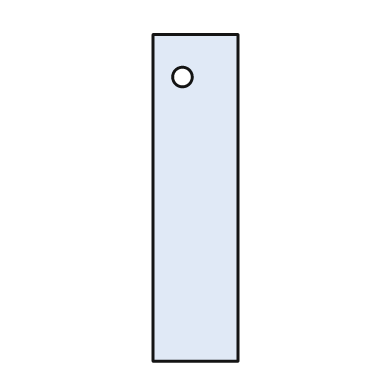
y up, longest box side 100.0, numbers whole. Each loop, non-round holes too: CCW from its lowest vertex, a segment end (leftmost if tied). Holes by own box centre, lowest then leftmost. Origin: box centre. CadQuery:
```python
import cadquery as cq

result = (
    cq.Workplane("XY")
    .moveTo(-13.0, -50.0)
    .lineTo(13.0, -50.0)
    .lineTo(13.0, 50.0)
    .lineTo(-13.0, 50.0)
    .close()
    .moveTo(-4.0, 37.0)
    .circle(3.0)
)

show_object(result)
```